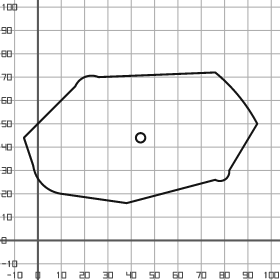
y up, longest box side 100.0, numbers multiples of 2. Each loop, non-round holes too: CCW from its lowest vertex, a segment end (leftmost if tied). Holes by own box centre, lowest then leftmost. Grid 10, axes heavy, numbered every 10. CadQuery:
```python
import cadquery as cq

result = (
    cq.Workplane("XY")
    .moveTo(38.0, 16.0)
    .lineTo(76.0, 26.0)
    .threePointArc((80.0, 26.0), (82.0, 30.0))
    .lineTo(94.0, 50.0)
    .threePointArc((86.0, 62.0), (76.0, 72.0))
    .lineTo(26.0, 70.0)
    .threePointArc((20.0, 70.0), (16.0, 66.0))
    .lineTo(-6.0, 44.0)
    .lineTo(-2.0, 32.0)
    .threePointArc((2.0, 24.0), (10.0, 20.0))
    .close()
    .moveTo(44.0, 44.0)
    .circle(2.0)
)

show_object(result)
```